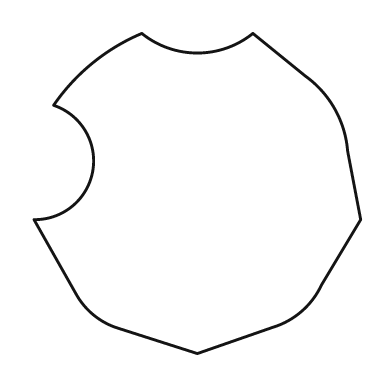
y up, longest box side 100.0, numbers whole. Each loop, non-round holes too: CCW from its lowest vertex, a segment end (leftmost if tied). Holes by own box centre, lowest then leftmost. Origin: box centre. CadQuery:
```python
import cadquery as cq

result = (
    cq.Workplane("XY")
    .moveTo(0.0, -49.0)
    .lineTo(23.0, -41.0)
    .threePointArc((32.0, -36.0), (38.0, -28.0))
    .lineTo(50.0, -8.0)
    .lineTo(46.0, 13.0)
    .threePointArc((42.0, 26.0), (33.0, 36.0))
    .lineTo(17.0, 49.0)
    .threePointArc((0.0, 43.0), (-17.0, 49.0))
    .threePointArc((-32.0, 40.0), (-44.0, 27.0))
    .threePointArc((-32.0, 7.0), (-50.0, -8.0))
    .lineTo(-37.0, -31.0)
    .threePointArc((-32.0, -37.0), (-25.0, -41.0))
    .close()
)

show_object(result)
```